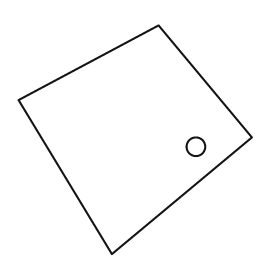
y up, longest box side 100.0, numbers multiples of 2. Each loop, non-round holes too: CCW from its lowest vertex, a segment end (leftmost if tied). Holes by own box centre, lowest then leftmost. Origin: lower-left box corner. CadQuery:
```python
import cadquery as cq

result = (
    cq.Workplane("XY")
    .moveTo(40.0, 0.0)
    .lineTo(100.0, 50.0)
    .lineTo(60.0, 98.0)
    .lineTo(0.0, 66.0)
    .close()
    .moveTo(76.0, 46.0)
    .circle(4.0)
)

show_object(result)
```